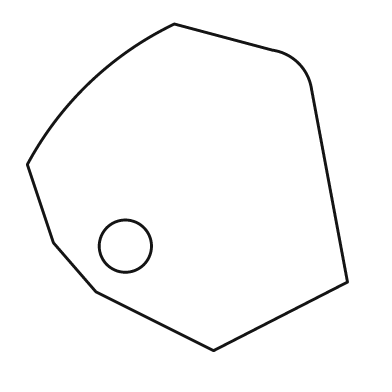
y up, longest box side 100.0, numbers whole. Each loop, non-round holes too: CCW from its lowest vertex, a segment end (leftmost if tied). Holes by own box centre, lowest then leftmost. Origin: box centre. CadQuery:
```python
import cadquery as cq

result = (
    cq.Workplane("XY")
    .moveTo(8.0, -50.0)
    .lineTo(49.0, -29.0)
    .lineTo(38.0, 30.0)
    .threePointArc((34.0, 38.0), (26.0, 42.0))
    .lineTo(-4.0, 50.0)
    .threePointArc((-30.0, 32.0), (-49.0, 7.0))
    .lineTo(-41.0, -17.0)
    .lineTo(-28.0, -32.0)
    .close()
    .moveTo(-19.0, -18.0)
    .circle(8.0)
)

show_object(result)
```